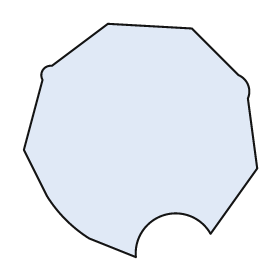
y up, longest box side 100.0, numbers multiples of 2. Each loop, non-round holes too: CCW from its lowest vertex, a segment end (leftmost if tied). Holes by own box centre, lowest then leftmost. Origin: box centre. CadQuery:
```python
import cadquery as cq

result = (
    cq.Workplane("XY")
    .moveTo(-2.0, -50.0)
    .threePointArc((10.0, -32.0), (30.0, -40.0))
    .lineTo(50.0, -12.0)
    .lineTo(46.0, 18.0)
    .threePointArc((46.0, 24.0), (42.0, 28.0))
    .lineTo(22.0, 48.0)
    .lineTo(-14.0, 50.0)
    .lineTo(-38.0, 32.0)
    .threePointArc((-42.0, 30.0), (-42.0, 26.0))
    .lineTo(-50.0, -4.0)
    .lineTo(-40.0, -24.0)
    .threePointArc((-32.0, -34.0), (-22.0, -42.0))
    .close()
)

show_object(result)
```